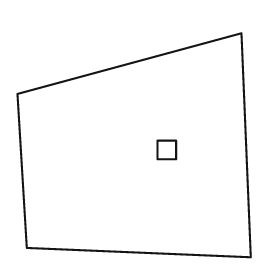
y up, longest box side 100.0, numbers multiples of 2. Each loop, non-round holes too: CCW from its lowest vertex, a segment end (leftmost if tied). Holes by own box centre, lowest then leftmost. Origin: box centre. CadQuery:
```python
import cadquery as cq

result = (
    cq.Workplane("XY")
    .moveTo(50.0, -48.0)
    .lineTo(46.0, 48.0)
    .lineTo(-50.0, 22.0)
    .lineTo(-46.0, -44.0)
    .close()
    .moveTo(10.0, -6.0)
    .lineTo(18.0, -6.0)
    .lineTo(18.0, 2.0)
    .lineTo(10.0, 2.0)
    .close()
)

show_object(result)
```